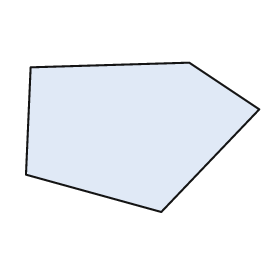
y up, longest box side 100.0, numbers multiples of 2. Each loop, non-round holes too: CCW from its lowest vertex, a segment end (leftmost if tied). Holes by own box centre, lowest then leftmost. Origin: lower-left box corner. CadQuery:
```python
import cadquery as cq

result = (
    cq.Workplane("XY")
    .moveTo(58.0, 0.0)
    .lineTo(100.0, 44.0)
    .lineTo(70.0, 64.0)
    .lineTo(2.0, 62.0)
    .lineTo(0.0, 16.0)
    .close()
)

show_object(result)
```